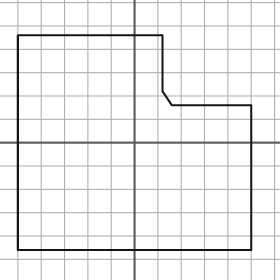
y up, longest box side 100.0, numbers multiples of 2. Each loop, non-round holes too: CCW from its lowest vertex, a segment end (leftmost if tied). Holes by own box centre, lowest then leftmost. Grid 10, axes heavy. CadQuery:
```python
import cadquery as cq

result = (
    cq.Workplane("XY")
    .moveTo(-50.0, -46.0)
    .lineTo(50.0, -46.0)
    .lineTo(50.0, 16.0)
    .lineTo(16.0, 16.0)
    .lineTo(12.0, 22.0)
    .lineTo(12.0, 46.0)
    .lineTo(-50.0, 46.0)
    .close()
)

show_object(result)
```